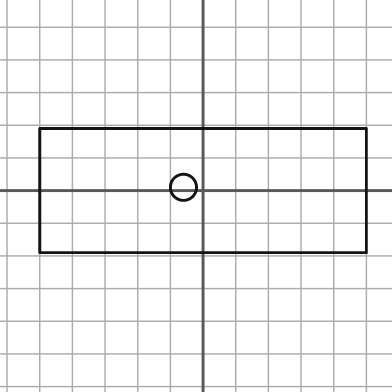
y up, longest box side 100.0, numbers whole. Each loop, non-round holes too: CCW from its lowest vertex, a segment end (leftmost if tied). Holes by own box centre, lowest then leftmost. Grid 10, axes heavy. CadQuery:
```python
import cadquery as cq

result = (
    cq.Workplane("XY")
    .moveTo(-50.0, -19.0)
    .lineTo(50.0, -19.0)
    .lineTo(50.0, 19.0)
    .lineTo(-50.0, 19.0)
    .close()
    .moveTo(-6.0, 1.0)
    .circle(4.0)
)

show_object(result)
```